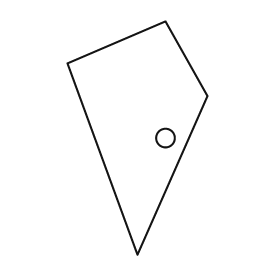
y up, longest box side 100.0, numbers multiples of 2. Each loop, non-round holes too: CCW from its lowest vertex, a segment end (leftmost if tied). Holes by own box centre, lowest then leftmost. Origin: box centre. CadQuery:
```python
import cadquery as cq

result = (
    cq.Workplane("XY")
    .moveTo(0.0, -50.0)
    .lineTo(30.0, 18.0)
    .lineTo(12.0, 50.0)
    .lineTo(-30.0, 32.0)
    .close()
    .moveTo(12.0, 0.0)
    .circle(4.0)
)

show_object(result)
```